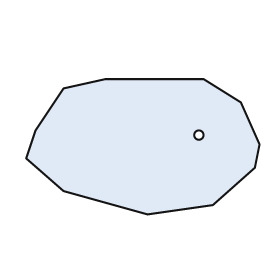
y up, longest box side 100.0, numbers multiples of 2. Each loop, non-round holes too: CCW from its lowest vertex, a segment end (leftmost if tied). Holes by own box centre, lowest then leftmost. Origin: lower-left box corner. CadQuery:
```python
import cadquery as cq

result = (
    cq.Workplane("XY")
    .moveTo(52.0, 0.0)
    .lineTo(80.0, 4.0)
    .lineTo(98.0, 20.0)
    .lineTo(100.0, 30.0)
    .lineTo(92.0, 48.0)
    .lineTo(76.0, 58.0)
    .lineTo(34.0, 58.0)
    .lineTo(16.0, 54.0)
    .lineTo(4.0, 36.0)
    .lineTo(0.0, 24.0)
    .lineTo(16.0, 10.0)
    .close()
    .moveTo(74.0, 34.0)
    .circle(2.0)
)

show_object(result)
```